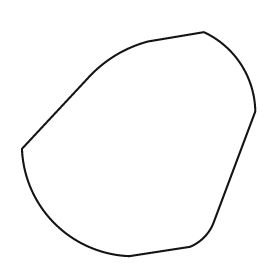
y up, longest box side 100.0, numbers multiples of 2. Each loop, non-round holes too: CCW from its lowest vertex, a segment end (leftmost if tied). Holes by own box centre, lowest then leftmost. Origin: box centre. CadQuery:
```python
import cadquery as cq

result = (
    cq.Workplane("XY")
    .moveTo(-4.0, -48.0)
    .lineTo(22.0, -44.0)
    .threePointArc((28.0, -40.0), (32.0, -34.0))
    .lineTo(50.0, 14.0)
    .threePointArc((44.0, 34.0), (28.0, 48.0))
    .lineTo(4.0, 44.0)
    .threePointArc((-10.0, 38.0), (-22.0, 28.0))
    .lineTo(-50.0, -2.0)
    .threePointArc((-36.0, -34.0), (-4.0, -48.0))
    .close()
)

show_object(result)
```